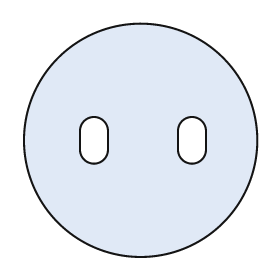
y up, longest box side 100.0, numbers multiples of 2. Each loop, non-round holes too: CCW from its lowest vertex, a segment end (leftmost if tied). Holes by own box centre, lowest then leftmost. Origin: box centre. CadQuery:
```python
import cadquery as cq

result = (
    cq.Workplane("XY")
    .moveTo(0.0, 0.0)
    .circle(50.0)
    .moveTo(-26.0, -4.0)
    .threePointArc((-20.0, -10.0), (-14.0, -4.0))
    .lineTo(-14.0, 4.0)
    .threePointArc((-20.0, 10.0), (-26.0, 4.0))
    .close()
    .moveTo(16.0, -4.0)
    .threePointArc((22.0, -10.0), (28.0, -4.0))
    .lineTo(28.0, 4.0)
    .threePointArc((22.0, 10.0), (16.0, 4.0))
    .close()
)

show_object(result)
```